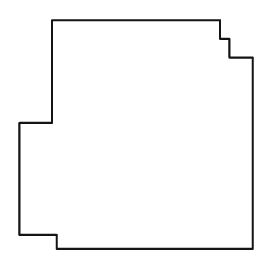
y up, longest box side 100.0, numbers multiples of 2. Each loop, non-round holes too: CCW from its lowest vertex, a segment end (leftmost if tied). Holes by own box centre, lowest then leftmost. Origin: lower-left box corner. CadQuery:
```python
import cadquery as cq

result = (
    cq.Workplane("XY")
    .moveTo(16.0, 0.0)
    .lineTo(100.0, 0.0)
    .lineTo(100.0, 82.0)
    .lineTo(90.0, 82.0)
    .lineTo(90.0, 90.0)
    .lineTo(86.0, 90.0)
    .lineTo(86.0, 98.0)
    .lineTo(14.0, 98.0)
    .lineTo(14.0, 54.0)
    .lineTo(0.0, 54.0)
    .lineTo(0.0, 6.0)
    .lineTo(16.0, 6.0)
    .close()
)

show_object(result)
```